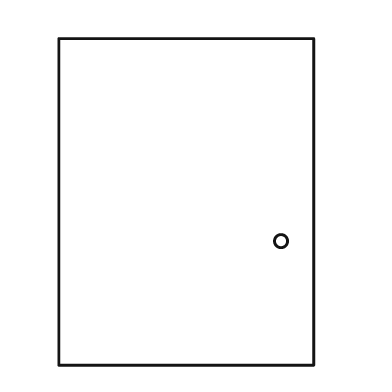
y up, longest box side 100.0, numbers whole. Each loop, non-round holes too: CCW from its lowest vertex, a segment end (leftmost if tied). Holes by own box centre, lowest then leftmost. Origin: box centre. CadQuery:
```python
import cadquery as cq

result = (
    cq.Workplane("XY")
    .moveTo(-39.0, -50.0)
    .lineTo(39.0, -50.0)
    .lineTo(39.0, 50.0)
    .lineTo(-39.0, 50.0)
    .close()
    .moveTo(29.0, -12.0)
    .circle(2.0)
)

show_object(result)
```